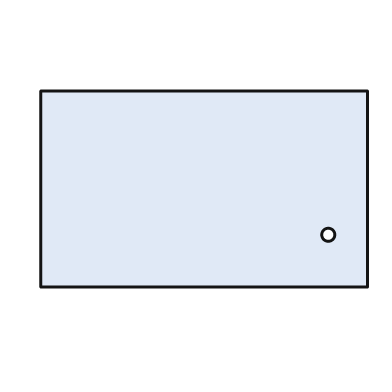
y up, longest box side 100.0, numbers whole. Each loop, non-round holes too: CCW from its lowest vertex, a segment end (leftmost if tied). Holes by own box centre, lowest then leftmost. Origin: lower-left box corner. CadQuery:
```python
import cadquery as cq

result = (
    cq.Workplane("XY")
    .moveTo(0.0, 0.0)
    .lineTo(100.0, 0.0)
    .lineTo(100.0, 60.0)
    .lineTo(0.0, 60.0)
    .close()
    .moveTo(88.0, 16.0)
    .circle(2.0)
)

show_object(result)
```